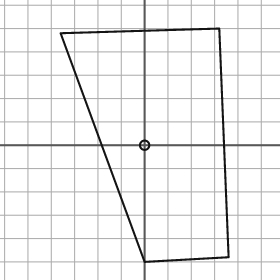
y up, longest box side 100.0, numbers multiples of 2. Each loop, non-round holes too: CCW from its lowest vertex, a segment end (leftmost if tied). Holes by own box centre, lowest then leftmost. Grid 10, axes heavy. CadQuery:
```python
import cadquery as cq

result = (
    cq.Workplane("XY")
    .moveTo(0.0, -50.0)
    .lineTo(36.0, -48.0)
    .lineTo(32.0, 50.0)
    .lineTo(-36.0, 48.0)
    .close()
    .moveTo(0.0, 0.0)
    .circle(2.0)
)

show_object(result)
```